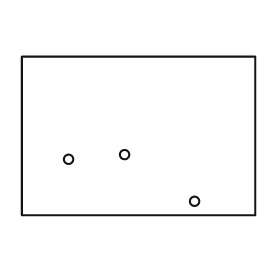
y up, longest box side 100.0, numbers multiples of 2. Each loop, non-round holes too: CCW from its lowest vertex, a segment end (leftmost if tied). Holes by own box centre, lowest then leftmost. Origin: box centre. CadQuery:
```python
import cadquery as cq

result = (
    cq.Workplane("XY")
    .moveTo(-50.0, -34.0)
    .lineTo(50.0, -34.0)
    .lineTo(50.0, 34.0)
    .lineTo(-50.0, 34.0)
    .close()
    .moveTo(24.0, -28.0)
    .circle(2.0)
    .moveTo(-30.0, -10.0)
    .circle(2.0)
    .moveTo(-6.0, -8.0)
    .circle(2.0)
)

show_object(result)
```